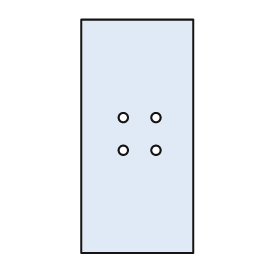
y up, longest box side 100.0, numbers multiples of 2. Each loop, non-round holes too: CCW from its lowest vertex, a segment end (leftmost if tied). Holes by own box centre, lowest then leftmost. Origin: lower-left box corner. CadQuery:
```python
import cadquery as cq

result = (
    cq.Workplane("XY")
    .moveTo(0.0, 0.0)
    .lineTo(48.0, 0.0)
    .lineTo(48.0, 100.0)
    .lineTo(0.0, 100.0)
    .close()
    .moveTo(18.0, 44.0)
    .circle(2.0)
    .moveTo(32.0, 44.0)
    .circle(2.0)
    .moveTo(18.0, 58.0)
    .circle(2.0)
    .moveTo(32.0, 58.0)
    .circle(2.0)
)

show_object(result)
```